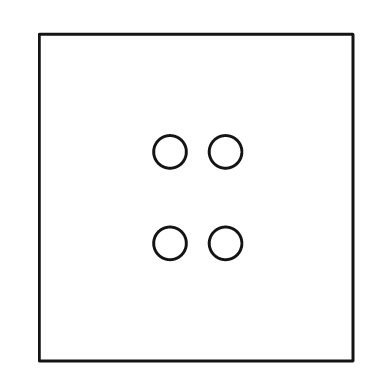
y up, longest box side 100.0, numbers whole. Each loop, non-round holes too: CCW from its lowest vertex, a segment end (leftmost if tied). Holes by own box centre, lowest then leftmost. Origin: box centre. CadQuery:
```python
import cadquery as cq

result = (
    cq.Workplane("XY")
    .moveTo(-48.0, -50.0)
    .lineTo(48.0, -50.0)
    .lineTo(48.0, 50.0)
    .lineTo(-48.0, 50.0)
    .close()
    .moveTo(-8.0, -14.0)
    .circle(5.0)
    .moveTo(9.0, -14.0)
    .circle(5.0)
    .moveTo(-8.0, 14.0)
    .circle(5.0)
    .moveTo(9.0, 14.0)
    .circle(5.0)
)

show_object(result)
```